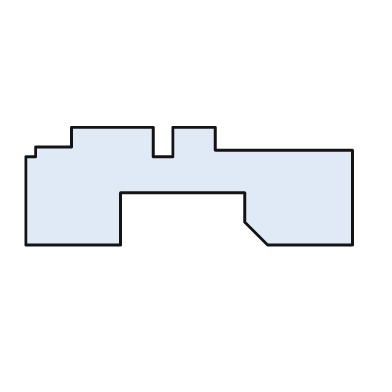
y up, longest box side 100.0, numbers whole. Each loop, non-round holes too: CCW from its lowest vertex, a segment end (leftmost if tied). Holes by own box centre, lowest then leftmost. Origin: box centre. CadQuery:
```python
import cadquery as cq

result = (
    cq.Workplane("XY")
    .moveTo(-50.0, -18.0)
    .lineTo(-21.0, -18.0)
    .lineTo(-21.0, -2.0)
    .lineTo(17.0, -2.0)
    .lineTo(17.0, -11.0)
    .lineTo(24.0, -18.0)
    .lineTo(50.0, -18.0)
    .lineTo(50.0, 11.0)
    .lineTo(8.0, 11.0)
    .lineTo(8.0, 18.0)
    .lineTo(-5.0, 18.0)
    .lineTo(-5.0, 9.0)
    .lineTo(-11.0, 9.0)
    .lineTo(-11.0, 18.0)
    .lineTo(-36.0, 18.0)
    .lineTo(-36.0, 12.0)
    .lineTo(-47.0, 12.0)
    .lineTo(-47.0, 9.0)
    .lineTo(-50.0, 9.0)
    .close()
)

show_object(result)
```